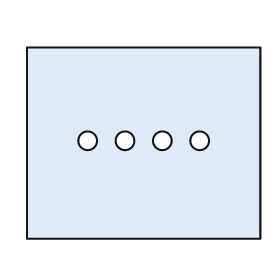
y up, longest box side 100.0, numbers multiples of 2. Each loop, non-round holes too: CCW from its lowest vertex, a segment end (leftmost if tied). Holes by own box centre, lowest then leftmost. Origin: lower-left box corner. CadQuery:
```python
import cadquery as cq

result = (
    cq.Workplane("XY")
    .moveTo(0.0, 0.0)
    .lineTo(100.0, 0.0)
    .lineTo(100.0, 82.0)
    .lineTo(0.0, 82.0)
    .close()
    .moveTo(26.0, 42.0)
    .circle(4.0)
    .moveTo(42.0, 42.0)
    .circle(4.0)
    .moveTo(58.0, 42.0)
    .circle(4.0)
    .moveTo(74.0, 42.0)
    .circle(4.0)
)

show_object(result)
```